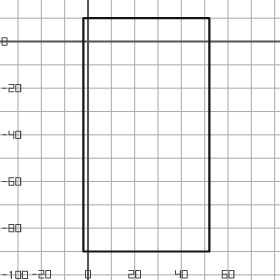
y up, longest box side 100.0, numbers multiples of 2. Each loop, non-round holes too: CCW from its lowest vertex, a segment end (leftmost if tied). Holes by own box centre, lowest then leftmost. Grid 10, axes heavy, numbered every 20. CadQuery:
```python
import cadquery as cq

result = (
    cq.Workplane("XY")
    .moveTo(-2.0, -90.0)
    .lineTo(52.0, -90.0)
    .lineTo(52.0, 10.0)
    .lineTo(-2.0, 10.0)
    .close()
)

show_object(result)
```